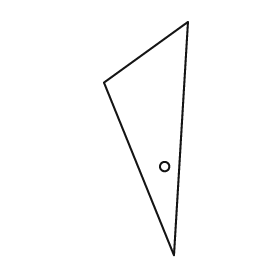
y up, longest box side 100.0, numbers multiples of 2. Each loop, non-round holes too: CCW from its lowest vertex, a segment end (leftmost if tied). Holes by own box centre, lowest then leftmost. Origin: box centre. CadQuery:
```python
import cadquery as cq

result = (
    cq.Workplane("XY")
    .moveTo(12.0, -50.0)
    .lineTo(18.0, 50.0)
    .lineTo(-18.0, 24.0)
    .close()
    .moveTo(8.0, -12.0)
    .circle(2.0)
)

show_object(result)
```